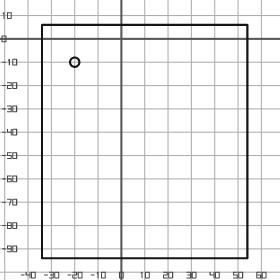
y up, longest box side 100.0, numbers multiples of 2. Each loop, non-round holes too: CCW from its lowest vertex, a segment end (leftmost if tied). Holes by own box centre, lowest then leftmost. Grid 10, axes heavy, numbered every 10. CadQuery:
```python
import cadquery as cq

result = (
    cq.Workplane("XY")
    .moveTo(-34.0, -94.0)
    .lineTo(54.0, -94.0)
    .lineTo(54.0, 6.0)
    .lineTo(-34.0, 6.0)
    .close()
    .moveTo(-20.0, -10.0)
    .circle(2.0)
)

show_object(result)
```